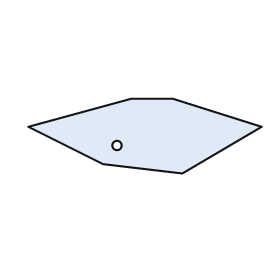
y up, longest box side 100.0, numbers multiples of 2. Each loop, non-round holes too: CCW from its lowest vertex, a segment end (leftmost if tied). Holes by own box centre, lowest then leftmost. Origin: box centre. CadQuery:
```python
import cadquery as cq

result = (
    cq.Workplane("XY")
    .moveTo(16.0, -16.0)
    .lineTo(50.0, 4.0)
    .lineTo(12.0, 16.0)
    .lineTo(-6.0, 16.0)
    .lineTo(-50.0, 4.0)
    .lineTo(-18.0, -12.0)
    .close()
    .moveTo(-12.0, -4.0)
    .circle(2.0)
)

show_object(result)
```